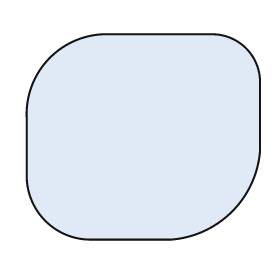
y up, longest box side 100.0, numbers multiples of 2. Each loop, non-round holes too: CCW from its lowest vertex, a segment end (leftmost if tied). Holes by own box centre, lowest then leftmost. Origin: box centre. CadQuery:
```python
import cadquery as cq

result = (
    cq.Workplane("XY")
    .moveTo(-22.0, -44.0)
    .lineTo(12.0, -44.0)
    .threePointArc((38.0, -32.0), (50.0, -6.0))
    .lineTo(50.0, 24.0)
    .threePointArc((44.0, 38.0), (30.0, 44.0))
    .lineTo(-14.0, 44.0)
    .threePointArc((-40.0, 34.0), (-50.0, 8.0))
    .lineTo(-50.0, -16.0)
    .threePointArc((-42.0, -36.0), (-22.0, -44.0))
    .close()
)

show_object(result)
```